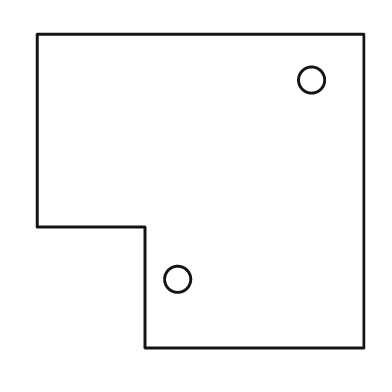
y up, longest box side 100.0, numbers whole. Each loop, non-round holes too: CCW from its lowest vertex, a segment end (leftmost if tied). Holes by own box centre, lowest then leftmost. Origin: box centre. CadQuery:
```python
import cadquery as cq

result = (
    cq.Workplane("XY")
    .moveTo(-17.0, -48.0)
    .lineTo(50.0, -48.0)
    .lineTo(50.0, 48.0)
    .lineTo(-50.0, 48.0)
    .lineTo(-50.0, -11.0)
    .lineTo(-17.0, -11.0)
    .close()
    .moveTo(-7.0, -27.0)
    .circle(4.0)
    .moveTo(34.0, 34.0)
    .circle(4.0)
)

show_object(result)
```